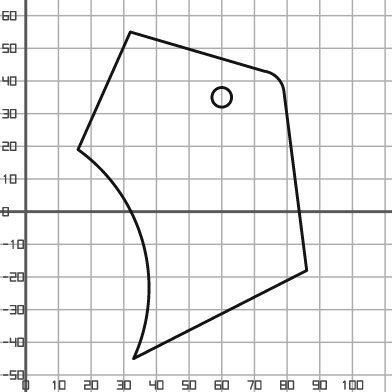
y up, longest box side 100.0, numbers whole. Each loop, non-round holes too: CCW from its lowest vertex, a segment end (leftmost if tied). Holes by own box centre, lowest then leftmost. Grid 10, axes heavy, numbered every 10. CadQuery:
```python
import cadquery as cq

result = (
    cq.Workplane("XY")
    .moveTo(33.0, -45.0)
    .lineTo(86.0, -18.0)
    .lineTo(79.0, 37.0)
    .threePointArc((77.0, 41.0), (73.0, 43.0))
    .lineTo(32.0, 55.0)
    .lineTo(16.0, 19.0)
    .threePointArc((36.0, -10.0), (33.0, -45.0))
    .close()
    .moveTo(60.0, 35.0)
    .circle(3.0)
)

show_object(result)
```